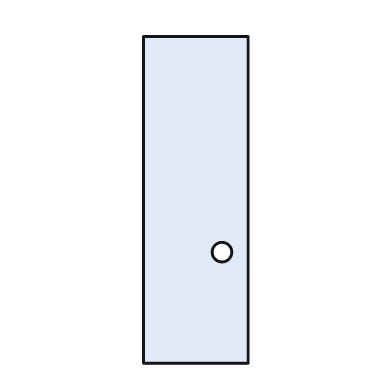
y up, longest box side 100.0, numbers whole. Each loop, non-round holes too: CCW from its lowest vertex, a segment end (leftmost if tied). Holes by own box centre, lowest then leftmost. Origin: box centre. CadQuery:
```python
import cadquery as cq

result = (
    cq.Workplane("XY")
    .moveTo(-16.0, -50.0)
    .lineTo(16.0, -50.0)
    .lineTo(16.0, 50.0)
    .lineTo(-16.0, 50.0)
    .close()
    .moveTo(8.0, -16.0)
    .circle(3.0)
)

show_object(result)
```